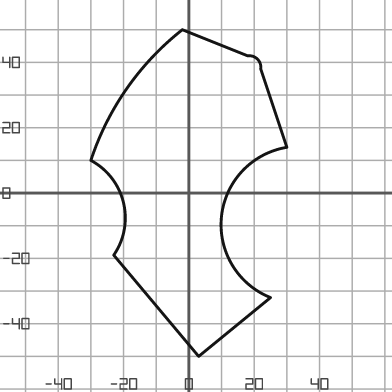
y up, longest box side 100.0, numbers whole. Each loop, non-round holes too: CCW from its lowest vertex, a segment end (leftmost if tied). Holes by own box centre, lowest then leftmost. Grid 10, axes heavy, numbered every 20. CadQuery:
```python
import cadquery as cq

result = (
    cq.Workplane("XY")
    .moveTo(3.0, -50.0)
    .lineTo(25.0, -32.0)
    .threePointArc((10.0, -7.0), (30.0, 14.0))
    .lineTo(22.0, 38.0)
    .threePointArc((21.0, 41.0), (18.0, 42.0))
    .lineTo(-2.0, 50.0)
    .threePointArc((-19.0, 32.0), (-30.0, 10.0))
    .threePointArc((-20.0, -3.0), (-23.0, -19.0))
    .close()
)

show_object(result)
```